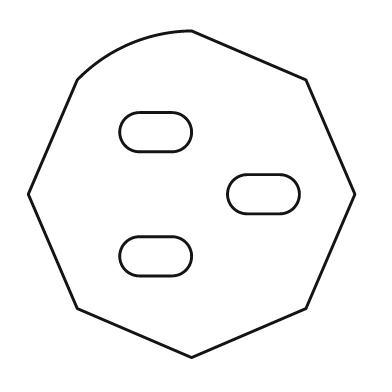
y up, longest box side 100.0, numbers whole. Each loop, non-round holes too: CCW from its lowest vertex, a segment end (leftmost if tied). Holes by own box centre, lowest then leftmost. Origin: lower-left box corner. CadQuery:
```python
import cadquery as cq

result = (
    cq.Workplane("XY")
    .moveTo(50.0, 0.0)
    .lineTo(85.0, 15.0)
    .lineTo(100.0, 50.0)
    .lineTo(85.0, 85.0)
    .lineTo(50.0, 100.0)
    .threePointArc((31.0, 96.0), (15.0, 85.0))
    .lineTo(0.0, 50.0)
    .lineTo(15.0, 15.0)
    .close()
    .moveTo(34.0, 25.0)
    .lineTo(44.0, 25.0)
    .threePointArc((50.0, 31.0), (44.0, 37.0))
    .lineTo(34.0, 37.0)
    .threePointArc((28.0, 31.0), (34.0, 25.0))
    .close()
    .moveTo(67.0, 44.0)
    .lineTo(77.0, 44.0)
    .threePointArc((83.0, 50.0), (77.0, 56.0))
    .lineTo(67.0, 56.0)
    .threePointArc((61.0, 50.0), (67.0, 44.0))
    .close()
    .moveTo(34.0, 63.0)
    .lineTo(44.0, 63.0)
    .threePointArc((50.0, 69.0), (44.0, 75.0))
    .lineTo(34.0, 75.0)
    .threePointArc((28.0, 69.0), (34.0, 63.0))
    .close()
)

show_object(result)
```